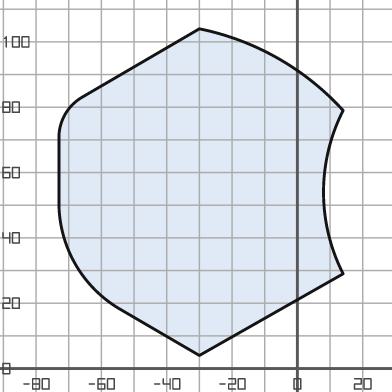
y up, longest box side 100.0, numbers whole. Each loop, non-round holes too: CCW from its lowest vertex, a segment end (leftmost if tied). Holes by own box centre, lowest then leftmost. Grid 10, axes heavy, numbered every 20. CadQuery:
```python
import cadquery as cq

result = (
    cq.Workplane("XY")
    .moveTo(-30.0, 4.0)
    .lineTo(14.0, 29.0)
    .threePointArc((8.0, 54.0), (14.0, 79.0))
    .threePointArc((-6.0, 95.0), (-30.0, 104.0))
    .lineTo(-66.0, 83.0)
    .threePointArc((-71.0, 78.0), (-73.0, 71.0))
    .lineTo(-73.0, 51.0)
    .threePointArc((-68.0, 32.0), (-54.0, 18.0))
    .close()
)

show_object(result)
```